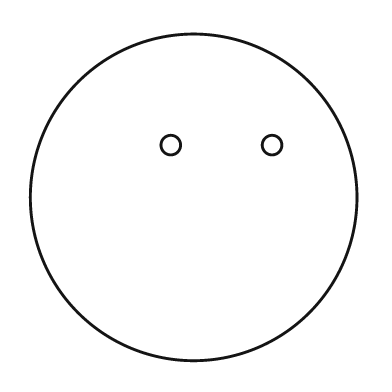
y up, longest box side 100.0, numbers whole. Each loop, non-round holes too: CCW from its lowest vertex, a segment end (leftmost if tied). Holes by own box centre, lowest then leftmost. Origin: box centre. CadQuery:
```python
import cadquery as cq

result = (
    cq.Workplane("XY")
    .moveTo(0.0, 0.0)
    .circle(50.0)
    .moveTo(-7.0, 16.0)
    .circle(3.0)
    .moveTo(24.0, 16.0)
    .circle(3.0)
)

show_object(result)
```